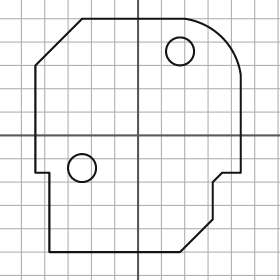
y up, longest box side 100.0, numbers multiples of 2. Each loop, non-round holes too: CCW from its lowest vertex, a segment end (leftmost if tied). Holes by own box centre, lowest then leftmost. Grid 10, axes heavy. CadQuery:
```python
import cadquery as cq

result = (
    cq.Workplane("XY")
    .moveTo(-38.0, -50.0)
    .lineTo(18.0, -50.0)
    .lineTo(32.0, -36.0)
    .lineTo(32.0, -20.0)
    .lineTo(36.0, -16.0)
    .lineTo(44.0, -16.0)
    .lineTo(44.0, 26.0)
    .threePointArc((36.0, 42.0), (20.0, 50.0))
    .lineTo(-24.0, 50.0)
    .lineTo(-44.0, 30.0)
    .lineTo(-44.0, -16.0)
    .lineTo(-38.0, -16.0)
    .close()
    .moveTo(-24.0, -14.0)
    .circle(6.0)
    .moveTo(18.0, 36.0)
    .circle(6.0)
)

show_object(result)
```